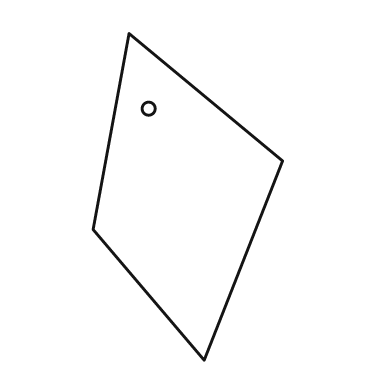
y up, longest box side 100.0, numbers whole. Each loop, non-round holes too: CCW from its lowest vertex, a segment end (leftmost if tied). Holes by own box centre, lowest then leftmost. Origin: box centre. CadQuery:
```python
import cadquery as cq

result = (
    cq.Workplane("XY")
    .moveTo(5.0, -50.0)
    .lineTo(29.0, 11.0)
    .lineTo(-18.0, 50.0)
    .lineTo(-29.0, -10.0)
    .close()
    .moveTo(-12.0, 27.0)
    .circle(2.0)
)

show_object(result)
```